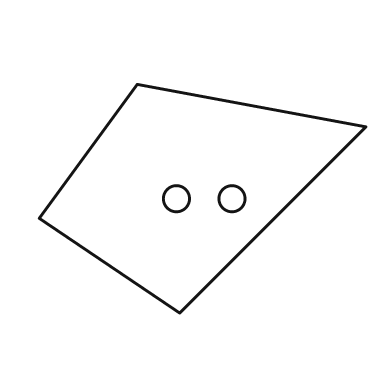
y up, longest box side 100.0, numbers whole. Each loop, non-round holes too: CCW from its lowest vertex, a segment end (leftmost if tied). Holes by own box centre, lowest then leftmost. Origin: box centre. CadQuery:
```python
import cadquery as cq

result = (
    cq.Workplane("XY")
    .moveTo(-7.0, -35.0)
    .lineTo(50.0, 22.0)
    .lineTo(-20.0, 35.0)
    .lineTo(-50.0, -6.0)
    .close()
    .moveTo(-8.0, 0.0)
    .circle(4.0)
    .moveTo(9.0, 0.0)
    .circle(4.0)
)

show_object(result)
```